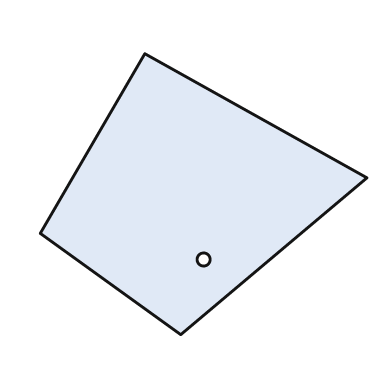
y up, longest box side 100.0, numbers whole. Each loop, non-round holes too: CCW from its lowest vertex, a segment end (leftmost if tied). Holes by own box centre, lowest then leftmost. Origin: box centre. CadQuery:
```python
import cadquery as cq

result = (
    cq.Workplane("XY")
    .moveTo(-7.0, -43.0)
    .lineTo(50.0, 5.0)
    .lineTo(-18.0, 43.0)
    .lineTo(-50.0, -12.0)
    .close()
    .moveTo(0.0, -20.0)
    .circle(2.0)
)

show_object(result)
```